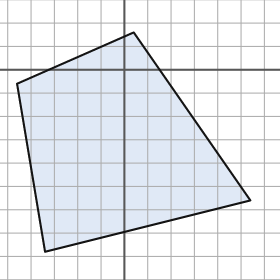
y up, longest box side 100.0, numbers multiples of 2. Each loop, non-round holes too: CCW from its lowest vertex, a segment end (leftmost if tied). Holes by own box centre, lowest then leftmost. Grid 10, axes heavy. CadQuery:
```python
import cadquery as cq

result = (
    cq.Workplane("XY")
    .moveTo(-34.0, -78.0)
    .lineTo(54.0, -56.0)
    .lineTo(4.0, 16.0)
    .lineTo(-46.0, -6.0)
    .close()
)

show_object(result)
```